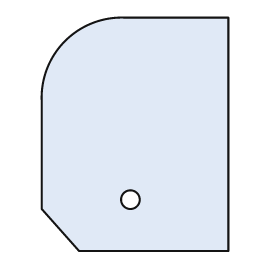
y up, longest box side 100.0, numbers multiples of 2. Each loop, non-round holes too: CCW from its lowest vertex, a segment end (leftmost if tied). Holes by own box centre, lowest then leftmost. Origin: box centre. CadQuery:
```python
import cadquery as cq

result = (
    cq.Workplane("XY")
    .moveTo(-24.0, -50.0)
    .lineTo(40.0, -50.0)
    .lineTo(40.0, 50.0)
    .lineTo(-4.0, 50.0)
    .threePointArc((-30.0, 40.0), (-40.0, 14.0))
    .lineTo(-40.0, -32.0)
    .close()
    .moveTo(-2.0, -28.0)
    .circle(4.0)
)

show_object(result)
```